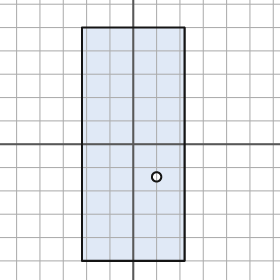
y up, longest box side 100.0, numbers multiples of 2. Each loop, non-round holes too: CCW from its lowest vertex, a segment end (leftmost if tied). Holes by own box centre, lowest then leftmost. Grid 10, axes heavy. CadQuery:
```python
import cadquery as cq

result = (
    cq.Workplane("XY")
    .moveTo(-22.0, -50.0)
    .lineTo(22.0, -50.0)
    .lineTo(22.0, 50.0)
    .lineTo(-22.0, 50.0)
    .close()
    .moveTo(10.0, -14.0)
    .circle(2.0)
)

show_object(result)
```